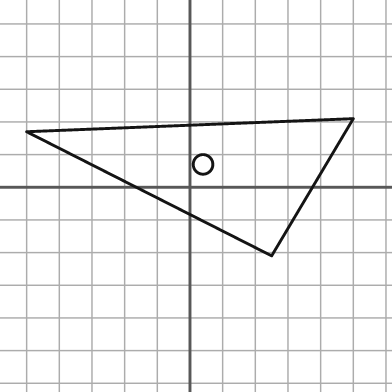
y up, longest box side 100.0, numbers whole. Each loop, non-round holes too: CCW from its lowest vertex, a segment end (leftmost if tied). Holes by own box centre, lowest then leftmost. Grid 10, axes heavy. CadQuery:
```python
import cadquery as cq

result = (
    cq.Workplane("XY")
    .moveTo(25.0, -21.0)
    .lineTo(50.0, 21.0)
    .lineTo(-50.0, 17.0)
    .close()
    .moveTo(4.0, 7.0)
    .circle(3.0)
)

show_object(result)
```